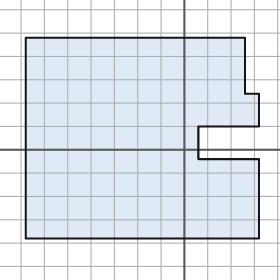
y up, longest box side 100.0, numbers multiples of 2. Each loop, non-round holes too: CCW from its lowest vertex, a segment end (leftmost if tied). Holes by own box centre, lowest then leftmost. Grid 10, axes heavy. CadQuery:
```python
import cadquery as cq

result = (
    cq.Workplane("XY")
    .moveTo(-68.0, -38.0)
    .lineTo(32.0, -38.0)
    .lineTo(32.0, -4.0)
    .lineTo(6.0, -4.0)
    .lineTo(6.0, 10.0)
    .lineTo(32.0, 10.0)
    .lineTo(32.0, 24.0)
    .lineTo(26.0, 24.0)
    .lineTo(26.0, 48.0)
    .lineTo(-68.0, 48.0)
    .close()
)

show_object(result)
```